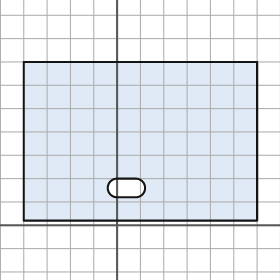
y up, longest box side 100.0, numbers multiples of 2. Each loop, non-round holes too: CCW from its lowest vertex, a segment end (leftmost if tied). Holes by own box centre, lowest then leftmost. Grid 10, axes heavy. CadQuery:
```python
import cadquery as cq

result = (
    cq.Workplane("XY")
    .moveTo(-40.0, 2.0)
    .lineTo(60.0, 2.0)
    .lineTo(60.0, 70.0)
    .lineTo(-40.0, 70.0)
    .close()
    .moveTo(0.0, 12.0)
    .lineTo(8.0, 12.0)
    .threePointArc((12.0, 16.0), (8.0, 20.0))
    .lineTo(0.0, 20.0)
    .threePointArc((-4.0, 16.0), (0.0, 12.0))
    .close()
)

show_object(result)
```